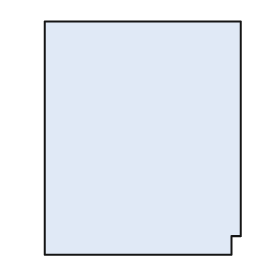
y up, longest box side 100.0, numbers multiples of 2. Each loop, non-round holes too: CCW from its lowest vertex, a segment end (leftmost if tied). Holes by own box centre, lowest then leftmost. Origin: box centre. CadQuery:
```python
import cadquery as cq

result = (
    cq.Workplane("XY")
    .moveTo(-42.0, -50.0)
    .lineTo(38.0, -50.0)
    .lineTo(38.0, -42.0)
    .lineTo(42.0, -42.0)
    .lineTo(42.0, 50.0)
    .lineTo(-42.0, 50.0)
    .close()
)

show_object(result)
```